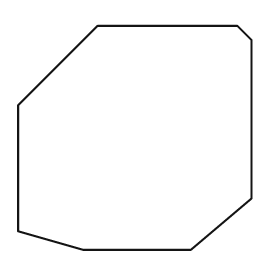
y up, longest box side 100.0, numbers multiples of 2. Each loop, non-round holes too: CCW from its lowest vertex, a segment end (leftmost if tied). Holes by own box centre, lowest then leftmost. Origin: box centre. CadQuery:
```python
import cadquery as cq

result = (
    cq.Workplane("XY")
    .moveTo(-22.0, -48.0)
    .lineTo(24.0, -48.0)
    .lineTo(50.0, -26.0)
    .lineTo(50.0, 42.0)
    .lineTo(44.0, 48.0)
    .lineTo(-16.0, 48.0)
    .lineTo(-50.0, 14.0)
    .lineTo(-50.0, -40.0)
    .close()
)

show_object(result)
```